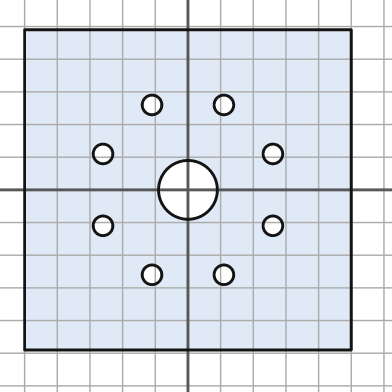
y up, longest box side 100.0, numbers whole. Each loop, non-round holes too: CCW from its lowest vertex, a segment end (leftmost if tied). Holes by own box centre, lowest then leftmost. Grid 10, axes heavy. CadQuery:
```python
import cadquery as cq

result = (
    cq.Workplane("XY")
    .moveTo(-50.0, -49.0)
    .lineTo(50.0, -49.0)
    .lineTo(50.0, 49.0)
    .lineTo(-50.0, 49.0)
    .close()
    .moveTo(-11.0, -26.0)
    .circle(3.0)
    .moveTo(11.0, -26.0)
    .circle(3.0)
    .moveTo(-26.0, -11.0)
    .circle(3.0)
    .moveTo(26.0, -11.0)
    .circle(3.0)
    .moveTo(0.0, 0.0)
    .circle(9.0)
    .moveTo(-26.0, 11.0)
    .circle(3.0)
    .moveTo(26.0, 11.0)
    .circle(3.0)
    .moveTo(-11.0, 26.0)
    .circle(3.0)
    .moveTo(11.0, 26.0)
    .circle(3.0)
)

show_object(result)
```